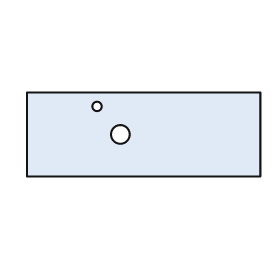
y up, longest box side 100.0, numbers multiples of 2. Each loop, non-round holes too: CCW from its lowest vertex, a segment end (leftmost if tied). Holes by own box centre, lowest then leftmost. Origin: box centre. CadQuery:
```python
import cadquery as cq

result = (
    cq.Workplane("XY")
    .moveTo(-50.0, -18.0)
    .lineTo(50.0, -18.0)
    .lineTo(50.0, 18.0)
    .lineTo(-50.0, 18.0)
    .close()
    .moveTo(-10.0, 0.0)
    .circle(4.0)
    .moveTo(-20.0, 12.0)
    .circle(2.0)
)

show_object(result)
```